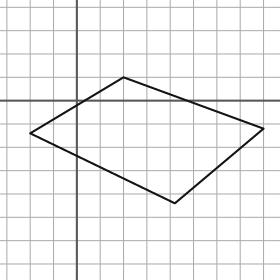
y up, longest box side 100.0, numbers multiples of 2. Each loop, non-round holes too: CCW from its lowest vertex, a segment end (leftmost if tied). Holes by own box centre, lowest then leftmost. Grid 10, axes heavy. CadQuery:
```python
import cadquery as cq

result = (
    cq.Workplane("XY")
    .moveTo(42.0, -44.0)
    .lineTo(80.0, -12.0)
    .lineTo(20.0, 10.0)
    .lineTo(-20.0, -14.0)
    .close()
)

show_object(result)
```